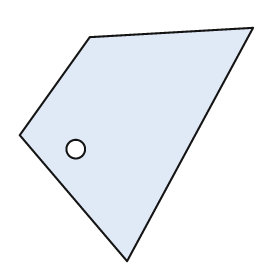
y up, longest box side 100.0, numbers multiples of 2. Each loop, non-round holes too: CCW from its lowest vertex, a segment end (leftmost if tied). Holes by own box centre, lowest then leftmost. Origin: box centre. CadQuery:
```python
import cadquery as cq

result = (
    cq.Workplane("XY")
    .moveTo(-4.0, -50.0)
    .lineTo(50.0, 50.0)
    .lineTo(-20.0, 46.0)
    .lineTo(-50.0, 4.0)
    .close()
    .moveTo(-26.0, -2.0)
    .circle(4.0)
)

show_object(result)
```